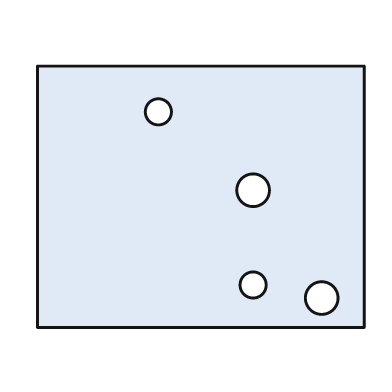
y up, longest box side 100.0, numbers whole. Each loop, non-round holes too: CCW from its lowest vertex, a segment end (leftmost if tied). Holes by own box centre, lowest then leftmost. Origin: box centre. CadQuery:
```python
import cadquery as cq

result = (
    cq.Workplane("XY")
    .moveTo(-50.0, -40.0)
    .lineTo(50.0, -40.0)
    .lineTo(50.0, 40.0)
    .lineTo(-50.0, 40.0)
    .close()
    .moveTo(37.0, -31.0)
    .circle(5.0)
    .moveTo(16.0, -27.0)
    .circle(4.0)
    .moveTo(16.0, 2.0)
    .circle(5.0)
    .moveTo(-13.0, 26.0)
    .circle(4.0)
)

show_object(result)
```